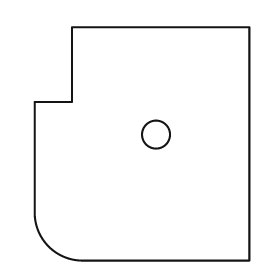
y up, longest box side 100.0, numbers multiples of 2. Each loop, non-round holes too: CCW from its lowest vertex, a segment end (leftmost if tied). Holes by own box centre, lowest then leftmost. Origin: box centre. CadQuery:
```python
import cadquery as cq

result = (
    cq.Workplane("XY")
    .moveTo(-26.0, -50.0)
    .lineTo(46.0, -50.0)
    .lineTo(46.0, 50.0)
    .lineTo(-30.0, 50.0)
    .lineTo(-30.0, 18.0)
    .lineTo(-46.0, 18.0)
    .lineTo(-46.0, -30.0)
    .threePointArc((-40.0, -44.0), (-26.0, -50.0))
    .close()
    .moveTo(6.0, 4.0)
    .circle(6.0)
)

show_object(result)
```